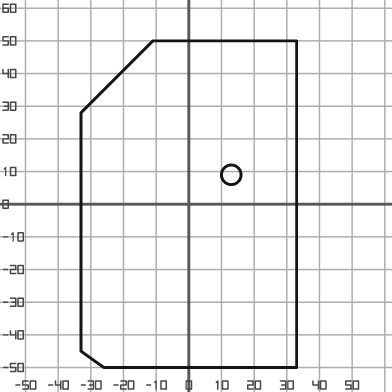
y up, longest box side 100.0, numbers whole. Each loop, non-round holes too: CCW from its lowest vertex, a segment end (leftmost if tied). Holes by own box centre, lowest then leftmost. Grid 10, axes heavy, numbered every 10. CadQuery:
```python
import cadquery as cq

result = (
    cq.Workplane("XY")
    .moveTo(-26.0, -50.0)
    .lineTo(33.0, -50.0)
    .lineTo(33.0, 50.0)
    .lineTo(-11.0, 50.0)
    .lineTo(-33.0, 28.0)
    .lineTo(-33.0, -45.0)
    .close()
    .moveTo(13.0, 9.0)
    .circle(3.0)
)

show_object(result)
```